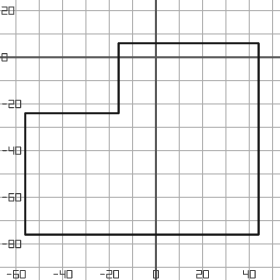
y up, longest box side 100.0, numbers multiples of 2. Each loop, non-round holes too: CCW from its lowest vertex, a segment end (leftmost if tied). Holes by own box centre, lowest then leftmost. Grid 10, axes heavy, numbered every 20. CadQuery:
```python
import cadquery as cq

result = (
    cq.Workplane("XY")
    .moveTo(-56.0, -76.0)
    .lineTo(44.0, -76.0)
    .lineTo(44.0, 6.0)
    .lineTo(-16.0, 6.0)
    .lineTo(-16.0, -24.0)
    .lineTo(-56.0, -24.0)
    .close()
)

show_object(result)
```